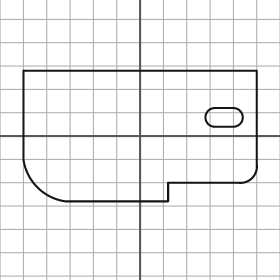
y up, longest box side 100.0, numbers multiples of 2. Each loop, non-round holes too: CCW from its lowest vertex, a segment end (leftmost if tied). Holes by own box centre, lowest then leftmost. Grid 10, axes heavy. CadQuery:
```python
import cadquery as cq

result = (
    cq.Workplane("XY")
    .moveTo(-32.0, -28.0)
    .lineTo(12.0, -28.0)
    .lineTo(12.0, -20.0)
    .lineTo(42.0, -20.0)
    .threePointArc((48.0, -18.0), (50.0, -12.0))
    .lineTo(50.0, 28.0)
    .lineTo(-50.0, 28.0)
    .lineTo(-50.0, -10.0)
    .threePointArc((-44.0, -22.0), (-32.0, -28.0))
    .close()
    .moveTo(32.0, 4.0)
    .lineTo(40.0, 4.0)
    .threePointArc((44.0, 8.0), (40.0, 12.0))
    .lineTo(32.0, 12.0)
    .threePointArc((28.0, 8.0), (32.0, 4.0))
    .close()
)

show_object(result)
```